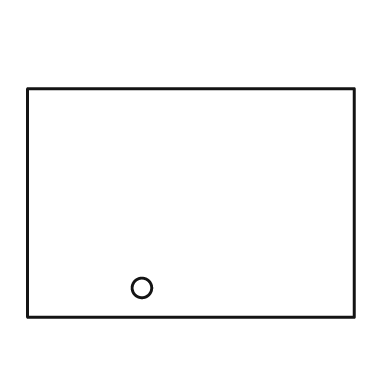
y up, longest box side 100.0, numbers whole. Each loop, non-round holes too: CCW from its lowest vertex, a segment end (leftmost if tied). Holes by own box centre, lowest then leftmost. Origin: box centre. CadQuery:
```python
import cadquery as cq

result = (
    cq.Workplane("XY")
    .moveTo(-50.0, -35.0)
    .lineTo(50.0, -35.0)
    .lineTo(50.0, 35.0)
    .lineTo(-50.0, 35.0)
    .close()
    .moveTo(-15.0, -26.0)
    .circle(3.0)
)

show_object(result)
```